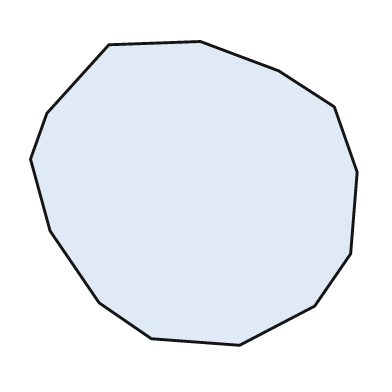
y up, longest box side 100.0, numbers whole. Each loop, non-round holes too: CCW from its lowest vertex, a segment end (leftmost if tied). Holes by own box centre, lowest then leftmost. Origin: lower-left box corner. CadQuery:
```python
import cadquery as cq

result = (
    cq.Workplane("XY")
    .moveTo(64.0, 0.0)
    .lineTo(87.0, 12.0)
    .lineTo(98.0, 28.0)
    .lineTo(100.0, 53.0)
    .lineTo(93.0, 73.0)
    .lineTo(76.0, 84.0)
    .lineTo(52.0, 93.0)
    .lineTo(24.0, 92.0)
    .lineTo(5.0, 71.0)
    .lineTo(0.0, 57.0)
    .lineTo(6.0, 35.0)
    .lineTo(21.0, 13.0)
    .lineTo(37.0, 2.0)
    .close()
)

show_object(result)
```